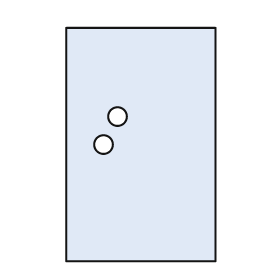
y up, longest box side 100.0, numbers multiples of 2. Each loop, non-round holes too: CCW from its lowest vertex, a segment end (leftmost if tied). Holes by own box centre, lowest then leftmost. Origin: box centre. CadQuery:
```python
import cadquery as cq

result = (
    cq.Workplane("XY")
    .moveTo(-32.0, -50.0)
    .lineTo(32.0, -50.0)
    .lineTo(32.0, 50.0)
    .lineTo(-32.0, 50.0)
    .close()
    .moveTo(-16.0, 0.0)
    .circle(4.0)
    .moveTo(-10.0, 12.0)
    .circle(4.0)
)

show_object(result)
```